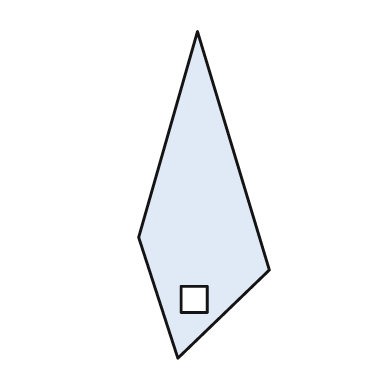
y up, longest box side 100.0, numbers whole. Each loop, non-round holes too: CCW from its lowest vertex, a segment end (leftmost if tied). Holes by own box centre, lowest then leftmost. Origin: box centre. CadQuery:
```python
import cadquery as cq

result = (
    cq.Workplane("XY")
    .moveTo(-8.0, -50.0)
    .lineTo(20.0, -23.0)
    .lineTo(-2.0, 50.0)
    .lineTo(-20.0, -13.0)
    .close()
    .moveTo(-7.0, -36.0)
    .lineTo(1.0, -36.0)
    .lineTo(1.0, -28.0)
    .lineTo(-7.0, -28.0)
    .close()
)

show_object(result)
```